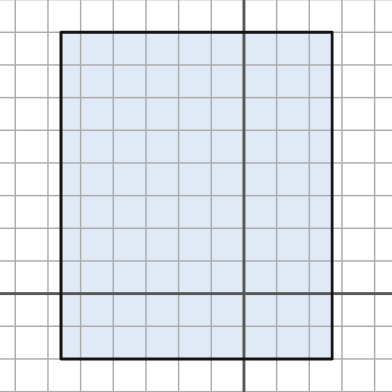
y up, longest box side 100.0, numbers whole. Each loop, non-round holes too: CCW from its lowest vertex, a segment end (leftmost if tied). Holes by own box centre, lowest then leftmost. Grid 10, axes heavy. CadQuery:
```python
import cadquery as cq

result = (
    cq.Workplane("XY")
    .moveTo(-56.0, -20.0)
    .lineTo(27.0, -20.0)
    .lineTo(27.0, 80.0)
    .lineTo(-56.0, 80.0)
    .close()
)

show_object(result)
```